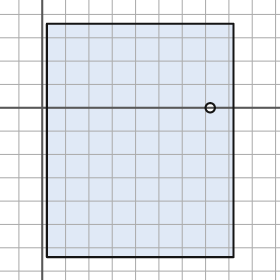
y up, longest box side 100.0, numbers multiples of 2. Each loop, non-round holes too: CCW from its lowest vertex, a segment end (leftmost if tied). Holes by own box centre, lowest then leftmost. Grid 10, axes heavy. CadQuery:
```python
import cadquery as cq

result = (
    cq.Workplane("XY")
    .moveTo(2.0, -64.0)
    .lineTo(82.0, -64.0)
    .lineTo(82.0, 36.0)
    .lineTo(2.0, 36.0)
    .close()
    .moveTo(72.0, 0.0)
    .circle(2.0)
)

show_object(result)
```